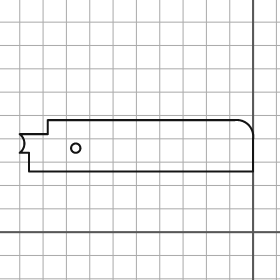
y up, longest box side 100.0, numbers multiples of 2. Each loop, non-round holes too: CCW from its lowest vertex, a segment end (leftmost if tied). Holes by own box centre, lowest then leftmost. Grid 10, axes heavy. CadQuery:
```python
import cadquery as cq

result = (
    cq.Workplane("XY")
    .moveTo(-96.0, 26.0)
    .lineTo(0.0, 26.0)
    .lineTo(0.0, 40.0)
    .threePointArc((-2.0, 46.0), (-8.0, 48.0))
    .lineTo(-88.0, 48.0)
    .lineTo(-88.0, 42.0)
    .lineTo(-100.0, 42.0)
    .threePointArc((-98.0, 38.0), (-100.0, 34.0))
    .lineTo(-96.0, 34.0)
    .close()
    .moveTo(-76.0, 36.0)
    .circle(2.0)
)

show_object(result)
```